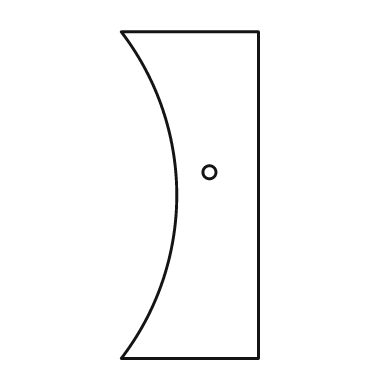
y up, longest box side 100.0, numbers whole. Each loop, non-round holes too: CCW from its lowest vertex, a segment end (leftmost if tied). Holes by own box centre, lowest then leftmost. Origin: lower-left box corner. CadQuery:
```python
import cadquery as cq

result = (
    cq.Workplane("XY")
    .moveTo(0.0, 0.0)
    .lineTo(42.0, 0.0)
    .lineTo(42.0, 100.0)
    .lineTo(0.0, 100.0)
    .threePointArc((17.0, 50.0), (0.0, 0.0))
    .close()
    .moveTo(27.0, 57.0)
    .circle(2.0)
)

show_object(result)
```